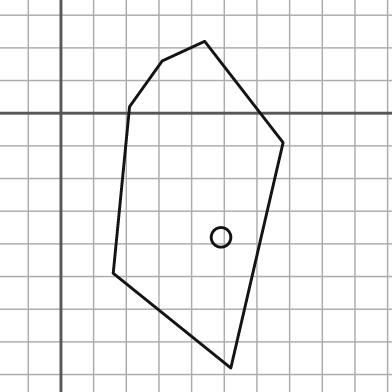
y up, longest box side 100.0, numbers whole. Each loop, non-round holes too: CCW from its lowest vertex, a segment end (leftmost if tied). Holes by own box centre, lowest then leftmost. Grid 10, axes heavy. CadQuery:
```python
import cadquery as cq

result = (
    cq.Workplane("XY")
    .moveTo(52.0, -78.0)
    .lineTo(68.0, -9.0)
    .lineTo(44.0, 22.0)
    .lineTo(31.0, 16.0)
    .lineTo(21.0, 2.0)
    .lineTo(16.0, -49.0)
    .close()
    .moveTo(49.0, -38.0)
    .circle(3.0)
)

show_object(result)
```